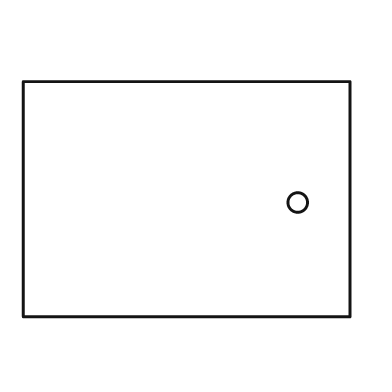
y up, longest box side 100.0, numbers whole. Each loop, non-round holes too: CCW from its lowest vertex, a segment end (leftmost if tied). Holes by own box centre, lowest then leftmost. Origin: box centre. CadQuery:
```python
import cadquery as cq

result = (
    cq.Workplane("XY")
    .moveTo(-50.0, -36.0)
    .lineTo(50.0, -36.0)
    .lineTo(50.0, 36.0)
    .lineTo(-50.0, 36.0)
    .close()
    .moveTo(34.0, -1.0)
    .circle(3.0)
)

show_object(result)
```